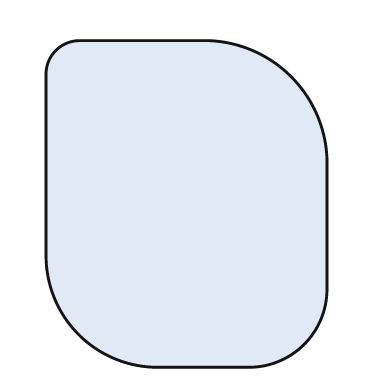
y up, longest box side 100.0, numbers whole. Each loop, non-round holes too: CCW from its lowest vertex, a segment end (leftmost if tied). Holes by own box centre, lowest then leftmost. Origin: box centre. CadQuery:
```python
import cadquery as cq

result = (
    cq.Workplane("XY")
    .moveTo(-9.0, -50.0)
    .lineTo(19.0, -50.0)
    .threePointArc((36.0, -43.0), (43.0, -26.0))
    .lineTo(43.0, 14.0)
    .threePointArc((32.0, 39.0), (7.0, 50.0))
    .lineTo(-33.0, 50.0)
    .threePointArc((-40.0, 47.0), (-43.0, 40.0))
    .lineTo(-43.0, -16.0)
    .threePointArc((-33.0, -40.0), (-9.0, -50.0))
    .close()
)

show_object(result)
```